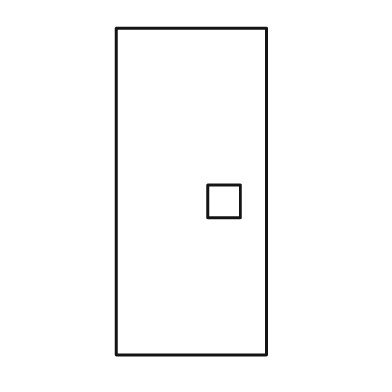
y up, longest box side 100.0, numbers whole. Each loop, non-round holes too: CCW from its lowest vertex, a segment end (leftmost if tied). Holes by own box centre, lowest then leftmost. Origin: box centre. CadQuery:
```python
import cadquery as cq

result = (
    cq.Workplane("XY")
    .moveTo(-23.0, -50.0)
    .lineTo(23.0, -50.0)
    .lineTo(23.0, 50.0)
    .lineTo(-23.0, 50.0)
    .close()
    .moveTo(5.0, -8.0)
    .lineTo(15.0, -8.0)
    .lineTo(15.0, 2.0)
    .lineTo(5.0, 2.0)
    .close()
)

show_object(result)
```